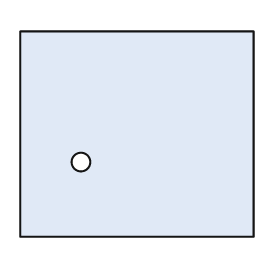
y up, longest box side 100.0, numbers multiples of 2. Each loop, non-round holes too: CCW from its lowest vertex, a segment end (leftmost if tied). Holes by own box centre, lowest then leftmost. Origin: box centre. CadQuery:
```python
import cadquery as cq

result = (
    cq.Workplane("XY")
    .moveTo(-50.0, -44.0)
    .lineTo(50.0, -44.0)
    .lineTo(50.0, 44.0)
    .lineTo(-50.0, 44.0)
    .close()
    .moveTo(-24.0, -12.0)
    .circle(4.0)
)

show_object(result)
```